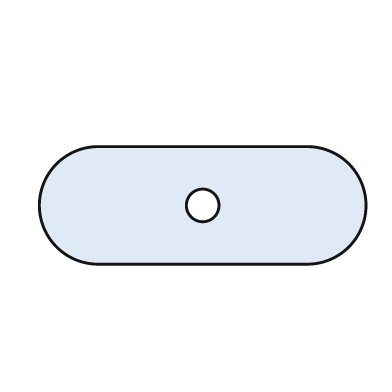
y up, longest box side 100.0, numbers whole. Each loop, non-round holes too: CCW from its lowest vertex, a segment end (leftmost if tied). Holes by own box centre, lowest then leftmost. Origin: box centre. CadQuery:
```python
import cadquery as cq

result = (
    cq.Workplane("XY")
    .moveTo(-32.0, -18.0)
    .lineTo(32.0, -18.0)
    .threePointArc((50.0, 0.0), (32.0, 18.0))
    .lineTo(-32.0, 18.0)
    .threePointArc((-50.0, 0.0), (-32.0, -18.0))
    .close()
    .moveTo(0.0, 0.0)
    .circle(5.0)
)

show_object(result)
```